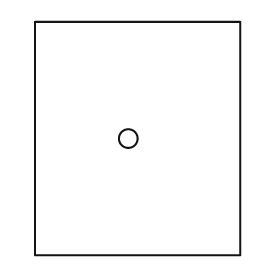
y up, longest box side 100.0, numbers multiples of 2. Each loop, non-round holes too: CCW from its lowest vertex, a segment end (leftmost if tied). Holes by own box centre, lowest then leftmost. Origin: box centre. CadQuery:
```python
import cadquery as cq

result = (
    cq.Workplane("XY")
    .moveTo(-44.0, -50.0)
    .lineTo(44.0, -50.0)
    .lineTo(44.0, 50.0)
    .lineTo(-44.0, 50.0)
    .close()
    .moveTo(-4.0, 0.0)
    .circle(4.0)
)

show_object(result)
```